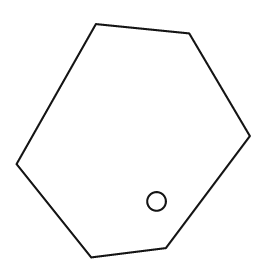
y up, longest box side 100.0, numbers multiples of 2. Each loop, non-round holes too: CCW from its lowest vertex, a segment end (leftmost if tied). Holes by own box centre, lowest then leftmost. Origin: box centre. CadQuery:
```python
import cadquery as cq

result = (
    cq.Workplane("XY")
    .moveTo(-18.0, -50.0)
    .lineTo(14.0, -46.0)
    .lineTo(50.0, 2.0)
    .lineTo(24.0, 46.0)
    .lineTo(-16.0, 50.0)
    .lineTo(-50.0, -10.0)
    .close()
    .moveTo(10.0, -26.0)
    .circle(4.0)
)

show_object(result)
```